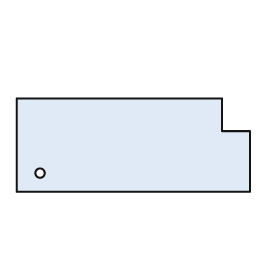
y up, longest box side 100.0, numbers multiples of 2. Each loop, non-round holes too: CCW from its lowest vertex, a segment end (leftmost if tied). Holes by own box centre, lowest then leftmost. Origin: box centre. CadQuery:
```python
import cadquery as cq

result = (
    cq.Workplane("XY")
    .moveTo(-50.0, -20.0)
    .lineTo(50.0, -20.0)
    .lineTo(50.0, 6.0)
    .lineTo(38.0, 6.0)
    .lineTo(38.0, 20.0)
    .lineTo(-50.0, 20.0)
    .close()
    .moveTo(-40.0, -12.0)
    .circle(2.0)
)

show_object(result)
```